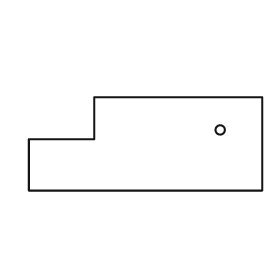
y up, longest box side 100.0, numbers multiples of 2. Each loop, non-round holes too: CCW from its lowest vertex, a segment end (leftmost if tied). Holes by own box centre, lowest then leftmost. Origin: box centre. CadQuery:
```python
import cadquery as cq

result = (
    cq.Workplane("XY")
    .moveTo(-50.0, -20.0)
    .lineTo(50.0, -20.0)
    .lineTo(50.0, 20.0)
    .lineTo(-22.0, 20.0)
    .lineTo(-22.0, 2.0)
    .lineTo(-50.0, 2.0)
    .close()
    .moveTo(32.0, 6.0)
    .circle(2.0)
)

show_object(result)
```